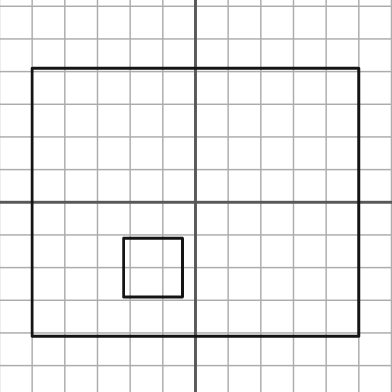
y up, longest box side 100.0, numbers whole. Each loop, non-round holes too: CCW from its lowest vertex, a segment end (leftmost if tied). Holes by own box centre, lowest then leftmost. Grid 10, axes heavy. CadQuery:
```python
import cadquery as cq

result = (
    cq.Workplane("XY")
    .moveTo(-50.0, -41.0)
    .lineTo(50.0, -41.0)
    .lineTo(50.0, 41.0)
    .lineTo(-50.0, 41.0)
    .close()
    .moveTo(-22.0, -29.0)
    .lineTo(-4.0, -29.0)
    .lineTo(-4.0, -11.0)
    .lineTo(-22.0, -11.0)
    .close()
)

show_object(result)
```